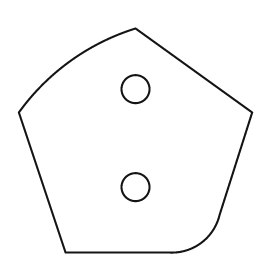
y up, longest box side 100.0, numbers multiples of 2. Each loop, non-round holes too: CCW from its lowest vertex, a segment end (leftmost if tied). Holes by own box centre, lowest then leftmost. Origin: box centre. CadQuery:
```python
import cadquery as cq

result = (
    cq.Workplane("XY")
    .moveTo(-30.0, -48.0)
    .lineTo(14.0, -48.0)
    .threePointArc((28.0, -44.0), (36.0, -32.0))
    .lineTo(50.0, 12.0)
    .lineTo(0.0, 48.0)
    .threePointArc((-28.0, 34.0), (-50.0, 12.0))
    .close()
    .moveTo(0.0, -20.0)
    .circle(6.0)
    .moveTo(0.0, 22.0)
    .circle(6.0)
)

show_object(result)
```